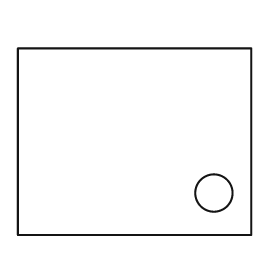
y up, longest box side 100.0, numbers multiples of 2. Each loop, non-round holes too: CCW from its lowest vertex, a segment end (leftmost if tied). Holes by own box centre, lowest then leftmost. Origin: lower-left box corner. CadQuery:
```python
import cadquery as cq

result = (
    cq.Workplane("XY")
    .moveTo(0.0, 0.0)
    .lineTo(100.0, 0.0)
    .lineTo(100.0, 80.0)
    .lineTo(0.0, 80.0)
    .close()
    .moveTo(84.0, 18.0)
    .circle(8.0)
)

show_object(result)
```